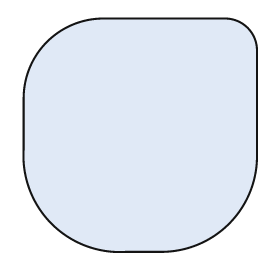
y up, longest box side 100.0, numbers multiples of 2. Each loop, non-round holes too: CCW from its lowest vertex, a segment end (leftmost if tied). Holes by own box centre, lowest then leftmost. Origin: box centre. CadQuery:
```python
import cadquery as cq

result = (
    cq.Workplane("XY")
    .moveTo(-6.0, -50.0)
    .lineTo(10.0, -50.0)
    .threePointArc((38.0, -38.0), (50.0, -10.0))
    .lineTo(50.0, 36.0)
    .threePointArc((46.0, 46.0), (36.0, 50.0))
    .lineTo(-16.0, 50.0)
    .threePointArc((-40.0, 40.0), (-50.0, 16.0))
    .lineTo(-50.0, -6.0)
    .threePointArc((-38.0, -38.0), (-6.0, -50.0))
    .close()
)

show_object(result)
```